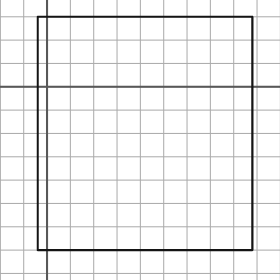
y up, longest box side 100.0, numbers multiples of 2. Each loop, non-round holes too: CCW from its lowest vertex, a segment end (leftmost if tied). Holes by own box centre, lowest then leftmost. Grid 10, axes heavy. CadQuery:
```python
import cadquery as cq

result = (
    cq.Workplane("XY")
    .moveTo(-4.0, -70.0)
    .lineTo(88.0, -70.0)
    .lineTo(88.0, 30.0)
    .lineTo(-4.0, 30.0)
    .close()
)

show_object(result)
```